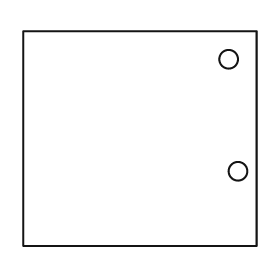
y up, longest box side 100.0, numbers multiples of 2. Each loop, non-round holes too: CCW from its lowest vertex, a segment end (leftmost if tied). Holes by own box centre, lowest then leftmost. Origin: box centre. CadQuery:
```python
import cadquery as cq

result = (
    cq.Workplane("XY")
    .moveTo(-50.0, -46.0)
    .lineTo(50.0, -46.0)
    .lineTo(50.0, 46.0)
    .lineTo(-50.0, 46.0)
    .close()
    .moveTo(42.0, -14.0)
    .circle(4.0)
    .moveTo(38.0, 34.0)
    .circle(4.0)
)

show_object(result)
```